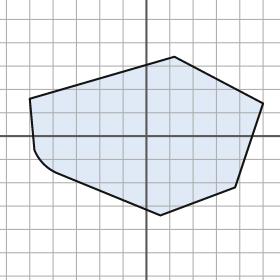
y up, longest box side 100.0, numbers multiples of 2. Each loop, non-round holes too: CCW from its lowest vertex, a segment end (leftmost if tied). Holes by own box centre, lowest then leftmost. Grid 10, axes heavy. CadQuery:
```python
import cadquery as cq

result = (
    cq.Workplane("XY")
    .moveTo(6.0, -34.0)
    .lineTo(38.0, -22.0)
    .lineTo(50.0, 14.0)
    .lineTo(12.0, 34.0)
    .lineTo(-50.0, 16.0)
    .lineTo(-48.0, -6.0)
    .threePointArc((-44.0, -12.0), (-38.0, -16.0))
    .close()
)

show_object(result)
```